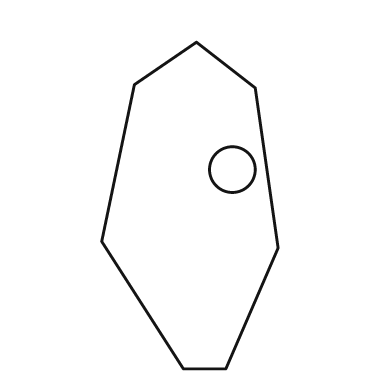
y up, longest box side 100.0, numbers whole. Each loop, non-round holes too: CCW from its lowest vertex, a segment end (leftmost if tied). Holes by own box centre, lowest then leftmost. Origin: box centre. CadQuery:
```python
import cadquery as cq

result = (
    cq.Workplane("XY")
    .moveTo(-2.0, -50.0)
    .lineTo(11.0, -50.0)
    .lineTo(27.0, -13.0)
    .lineTo(20.0, 36.0)
    .lineTo(2.0, 50.0)
    .lineTo(-17.0, 37.0)
    .lineTo(-27.0, -11.0)
    .close()
    .moveTo(13.0, 11.0)
    .circle(7.0)
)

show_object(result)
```